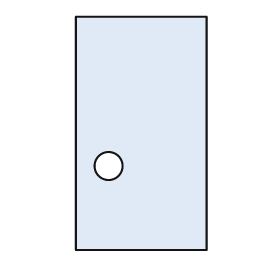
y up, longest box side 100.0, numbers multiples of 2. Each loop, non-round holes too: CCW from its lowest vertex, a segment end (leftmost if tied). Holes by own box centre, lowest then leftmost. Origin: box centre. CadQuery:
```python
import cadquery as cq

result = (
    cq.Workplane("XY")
    .moveTo(-28.0, -50.0)
    .lineTo(28.0, -50.0)
    .lineTo(28.0, 50.0)
    .lineTo(-28.0, 50.0)
    .close()
    .moveTo(-14.0, -14.0)
    .circle(6.0)
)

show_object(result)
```